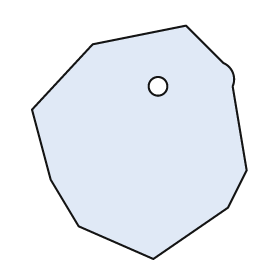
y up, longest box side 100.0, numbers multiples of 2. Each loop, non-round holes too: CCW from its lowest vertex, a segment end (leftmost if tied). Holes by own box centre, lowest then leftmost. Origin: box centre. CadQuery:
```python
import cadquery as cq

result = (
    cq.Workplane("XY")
    .moveTo(6.0, -50.0)
    .lineTo(38.0, -28.0)
    .lineTo(46.0, -12.0)
    .lineTo(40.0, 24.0)
    .threePointArc((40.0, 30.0), (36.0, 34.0))
    .lineTo(20.0, 50.0)
    .lineTo(-20.0, 42.0)
    .lineTo(-46.0, 14.0)
    .lineTo(-38.0, -16.0)
    .lineTo(-26.0, -36.0)
    .close()
    .moveTo(8.0, 24.0)
    .circle(4.0)
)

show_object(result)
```